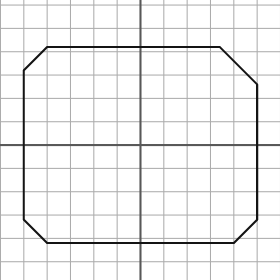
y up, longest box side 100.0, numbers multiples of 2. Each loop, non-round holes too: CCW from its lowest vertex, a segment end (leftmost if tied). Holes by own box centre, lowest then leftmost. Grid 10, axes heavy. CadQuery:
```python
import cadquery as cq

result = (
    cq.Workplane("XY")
    .moveTo(-40.0, -42.0)
    .lineTo(40.0, -42.0)
    .lineTo(50.0, -32.0)
    .lineTo(50.0, 26.0)
    .lineTo(34.0, 42.0)
    .lineTo(-40.0, 42.0)
    .lineTo(-50.0, 32.0)
    .lineTo(-50.0, -32.0)
    .close()
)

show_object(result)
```